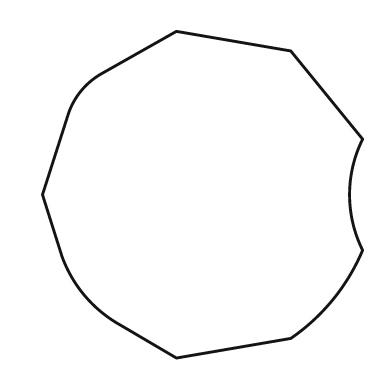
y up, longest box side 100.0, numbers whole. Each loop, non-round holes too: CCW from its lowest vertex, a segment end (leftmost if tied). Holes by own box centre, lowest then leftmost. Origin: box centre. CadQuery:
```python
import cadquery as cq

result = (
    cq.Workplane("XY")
    .moveTo(-8.0, -50.0)
    .lineTo(27.0, -44.0)
    .threePointArc((40.0, -32.0), (49.0, -17.0))
    .threePointArc((45.0, 0.0), (49.0, 17.0))
    .lineTo(27.0, 44.0)
    .lineTo(-8.0, 50.0)
    .lineTo(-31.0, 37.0)
    .threePointArc((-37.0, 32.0), (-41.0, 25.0))
    .lineTo(-49.0, 0.0)
    .lineTo(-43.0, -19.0)
    .threePointArc((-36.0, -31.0), (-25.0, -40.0))
    .close()
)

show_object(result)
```